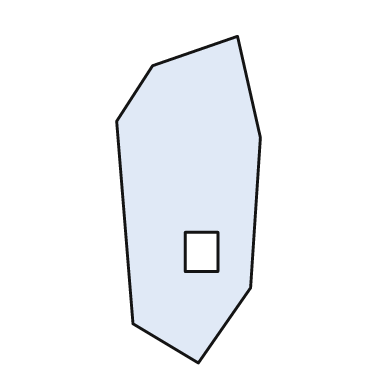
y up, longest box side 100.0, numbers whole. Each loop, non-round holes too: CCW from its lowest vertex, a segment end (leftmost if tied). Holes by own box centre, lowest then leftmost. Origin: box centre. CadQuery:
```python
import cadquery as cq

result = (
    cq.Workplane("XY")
    .moveTo(3.0, -50.0)
    .lineTo(19.0, -27.0)
    .lineTo(22.0, 19.0)
    .lineTo(15.0, 50.0)
    .lineTo(-11.0, 41.0)
    .lineTo(-22.0, 24.0)
    .lineTo(-17.0, -38.0)
    .close()
    .moveTo(-1.0, -22.0)
    .lineTo(9.0, -22.0)
    .lineTo(9.0, -10.0)
    .lineTo(-1.0, -10.0)
    .close()
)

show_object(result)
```